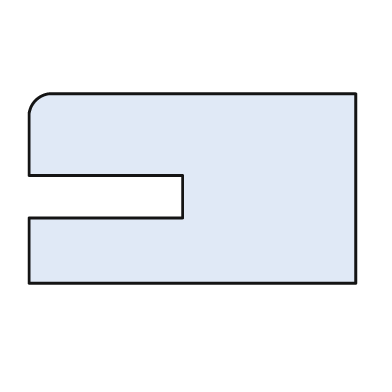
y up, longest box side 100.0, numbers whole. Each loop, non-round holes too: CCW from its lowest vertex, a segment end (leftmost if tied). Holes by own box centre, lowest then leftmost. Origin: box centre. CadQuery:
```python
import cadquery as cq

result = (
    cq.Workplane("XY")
    .moveTo(-50.0, -29.0)
    .lineTo(50.0, -29.0)
    .lineTo(50.0, 29.0)
    .lineTo(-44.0, 29.0)
    .threePointArc((-48.0, 27.0), (-50.0, 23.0))
    .lineTo(-50.0, 4.0)
    .lineTo(-3.0, 4.0)
    .lineTo(-3.0, -9.0)
    .lineTo(-50.0, -9.0)
    .close()
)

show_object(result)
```